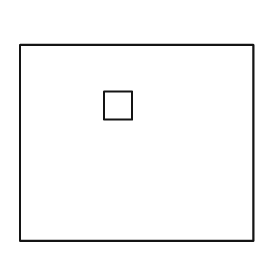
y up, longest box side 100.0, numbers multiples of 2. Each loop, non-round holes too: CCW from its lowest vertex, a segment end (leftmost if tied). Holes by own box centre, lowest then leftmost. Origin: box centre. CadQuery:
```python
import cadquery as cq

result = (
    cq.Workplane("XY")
    .moveTo(-50.0, -42.0)
    .lineTo(50.0, -42.0)
    .lineTo(50.0, 42.0)
    .lineTo(-50.0, 42.0)
    .close()
    .moveTo(-14.0, 10.0)
    .lineTo(-2.0, 10.0)
    .lineTo(-2.0, 22.0)
    .lineTo(-14.0, 22.0)
    .close()
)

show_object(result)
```